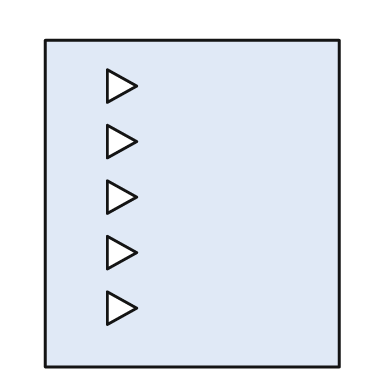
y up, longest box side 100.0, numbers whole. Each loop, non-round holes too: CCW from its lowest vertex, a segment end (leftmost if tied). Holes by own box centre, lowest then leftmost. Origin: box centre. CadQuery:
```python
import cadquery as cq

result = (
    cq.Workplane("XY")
    .moveTo(-45.0, -50.0)
    .lineTo(45.0, -50.0)
    .lineTo(45.0, 50.0)
    .lineTo(-45.0, 50.0)
    .close()
    .moveTo(-26.0, -37.0)
    .lineTo(-17.0, -32.0)
    .lineTo(-26.0, -27.0)
    .close()
    .moveTo(-26.0, -20.0)
    .lineTo(-17.0, -15.0)
    .lineTo(-26.0, -10.0)
    .close()
    .moveTo(-26.0, -3.0)
    .lineTo(-17.0, 2.0)
    .lineTo(-26.0, 7.0)
    .close()
    .moveTo(-26.0, 14.0)
    .lineTo(-17.0, 19.0)
    .lineTo(-26.0, 24.0)
    .close()
    .moveTo(-26.0, 31.0)
    .lineTo(-17.0, 36.0)
    .lineTo(-26.0, 41.0)
    .close()
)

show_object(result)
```